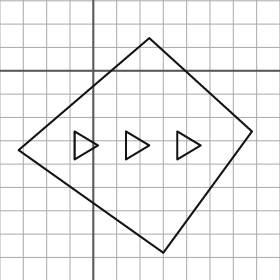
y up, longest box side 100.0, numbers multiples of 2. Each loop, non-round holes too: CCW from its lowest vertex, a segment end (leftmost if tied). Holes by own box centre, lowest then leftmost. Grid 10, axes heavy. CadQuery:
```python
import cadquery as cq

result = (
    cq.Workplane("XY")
    .moveTo(30.0, -78.0)
    .lineTo(68.0, -26.0)
    .lineTo(24.0, 14.0)
    .lineTo(-32.0, -34.0)
    .close()
    .moveTo(-8.0, -38.0)
    .lineTo(2.0, -32.0)
    .lineTo(-8.0, -26.0)
    .close()
    .moveTo(14.0, -38.0)
    .lineTo(24.0, -32.0)
    .lineTo(14.0, -26.0)
    .close()
    .moveTo(36.0, -38.0)
    .lineTo(46.0, -32.0)
    .lineTo(36.0, -26.0)
    .close()
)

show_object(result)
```